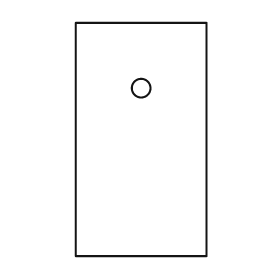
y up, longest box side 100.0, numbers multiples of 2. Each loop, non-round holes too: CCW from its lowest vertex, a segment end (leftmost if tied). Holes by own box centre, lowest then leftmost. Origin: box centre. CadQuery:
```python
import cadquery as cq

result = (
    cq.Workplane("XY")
    .moveTo(-28.0, -50.0)
    .lineTo(28.0, -50.0)
    .lineTo(28.0, 50.0)
    .lineTo(-28.0, 50.0)
    .close()
    .moveTo(0.0, 22.0)
    .circle(4.0)
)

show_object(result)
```